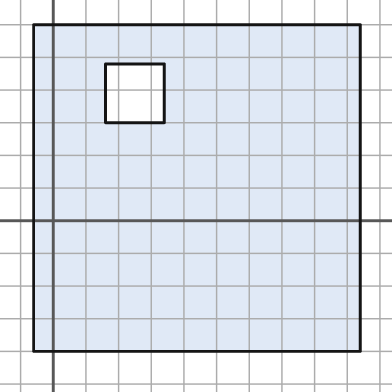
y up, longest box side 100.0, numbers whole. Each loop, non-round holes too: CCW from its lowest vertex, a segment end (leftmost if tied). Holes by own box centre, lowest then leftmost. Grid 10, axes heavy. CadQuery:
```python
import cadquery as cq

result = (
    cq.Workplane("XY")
    .moveTo(-6.0, -40.0)
    .lineTo(94.0, -40.0)
    .lineTo(94.0, 60.0)
    .lineTo(-6.0, 60.0)
    .close()
    .moveTo(16.0, 30.0)
    .lineTo(34.0, 30.0)
    .lineTo(34.0, 48.0)
    .lineTo(16.0, 48.0)
    .close()
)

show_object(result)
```